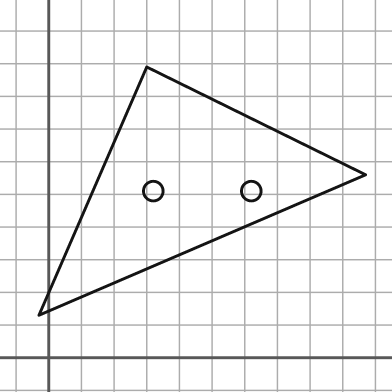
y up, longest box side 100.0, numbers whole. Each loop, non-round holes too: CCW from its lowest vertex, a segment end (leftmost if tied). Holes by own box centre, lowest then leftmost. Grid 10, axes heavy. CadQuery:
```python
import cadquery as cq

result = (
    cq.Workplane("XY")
    .moveTo(-3.0, 13.0)
    .lineTo(97.0, 56.0)
    .lineTo(30.0, 89.0)
    .close()
    .moveTo(32.0, 51.0)
    .circle(3.0)
    .moveTo(62.0, 51.0)
    .circle(3.0)
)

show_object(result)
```